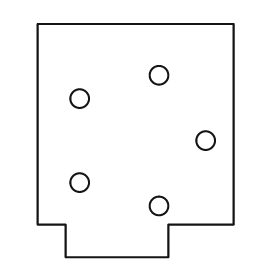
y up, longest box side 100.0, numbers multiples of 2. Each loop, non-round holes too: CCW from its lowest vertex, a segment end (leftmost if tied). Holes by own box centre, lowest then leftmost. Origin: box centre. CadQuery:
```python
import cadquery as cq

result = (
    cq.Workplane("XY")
    .moveTo(-30.0, -50.0)
    .lineTo(14.0, -50.0)
    .lineTo(14.0, -36.0)
    .lineTo(42.0, -36.0)
    .lineTo(42.0, 50.0)
    .lineTo(-42.0, 50.0)
    .lineTo(-42.0, -36.0)
    .lineTo(-30.0, -36.0)
    .close()
    .moveTo(10.0, -28.0)
    .circle(4.0)
    .moveTo(-24.0, -18.0)
    .circle(4.0)
    .moveTo(30.0, 0.0)
    .circle(4.0)
    .moveTo(-24.0, 18.0)
    .circle(4.0)
    .moveTo(10.0, 28.0)
    .circle(4.0)
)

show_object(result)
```